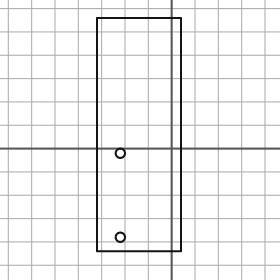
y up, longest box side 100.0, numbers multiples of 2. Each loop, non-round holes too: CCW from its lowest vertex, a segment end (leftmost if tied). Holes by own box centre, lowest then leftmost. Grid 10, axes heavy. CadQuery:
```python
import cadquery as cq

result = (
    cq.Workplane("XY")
    .moveTo(-32.0, -44.0)
    .lineTo(4.0, -44.0)
    .lineTo(4.0, 56.0)
    .lineTo(-32.0, 56.0)
    .close()
    .moveTo(-22.0, -38.0)
    .circle(2.0)
    .moveTo(-22.0, -2.0)
    .circle(2.0)
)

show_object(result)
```